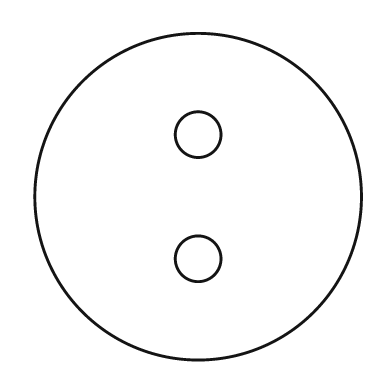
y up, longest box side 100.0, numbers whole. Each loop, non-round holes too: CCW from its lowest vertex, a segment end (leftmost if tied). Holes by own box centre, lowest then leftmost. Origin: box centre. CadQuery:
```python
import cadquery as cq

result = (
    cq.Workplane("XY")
    .moveTo(0.0, 0.0)
    .circle(50.0)
    .moveTo(0.0, -19.0)
    .circle(7.0)
    .moveTo(0.0, 19.0)
    .circle(7.0)
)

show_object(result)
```